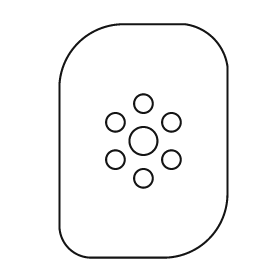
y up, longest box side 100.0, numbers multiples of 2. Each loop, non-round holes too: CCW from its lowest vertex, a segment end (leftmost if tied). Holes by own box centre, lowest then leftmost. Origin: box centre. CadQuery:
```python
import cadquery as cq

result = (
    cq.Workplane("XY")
    .moveTo(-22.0, -50.0)
    .lineTo(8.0, -50.0)
    .threePointArc((28.0, -42.0), (36.0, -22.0))
    .lineTo(36.0, 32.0)
    .threePointArc((30.0, 44.0), (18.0, 50.0))
    .lineTo(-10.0, 50.0)
    .threePointArc((-28.0, 42.0), (-36.0, 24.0))
    .lineTo(-36.0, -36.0)
    .threePointArc((-32.0, -46.0), (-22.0, -50.0))
    .close()
    .moveTo(0.0, -16.0)
    .circle(4.0)
    .moveTo(-12.0, -8.0)
    .circle(4.0)
    .moveTo(12.0, -8.0)
    .circle(4.0)
    .moveTo(0.0, 0.0)
    .circle(6.0)
    .moveTo(-12.0, 8.0)
    .circle(4.0)
    .moveTo(12.0, 8.0)
    .circle(4.0)
    .moveTo(0.0, 16.0)
    .circle(4.0)
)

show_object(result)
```